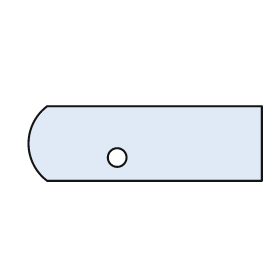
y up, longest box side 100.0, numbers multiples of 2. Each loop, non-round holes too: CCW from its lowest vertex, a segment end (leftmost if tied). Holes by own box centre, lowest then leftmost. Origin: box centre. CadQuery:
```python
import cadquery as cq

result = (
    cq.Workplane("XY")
    .moveTo(-42.0, -16.0)
    .lineTo(50.0, -16.0)
    .lineTo(50.0, 16.0)
    .lineTo(-42.0, 16.0)
    .threePointArc((-50.0, 0.0), (-42.0, -16.0))
    .close()
    .moveTo(-12.0, -6.0)
    .circle(4.0)
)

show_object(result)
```